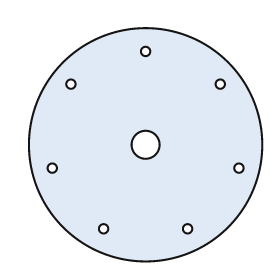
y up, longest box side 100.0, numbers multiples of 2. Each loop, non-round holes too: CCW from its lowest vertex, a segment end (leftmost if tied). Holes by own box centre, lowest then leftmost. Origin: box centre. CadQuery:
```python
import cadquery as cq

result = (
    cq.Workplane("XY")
    .moveTo(0.0, 0.0)
    .circle(50.0)
    .moveTo(-18.0, -36.0)
    .circle(2.0)
    .moveTo(18.0, -36.0)
    .circle(2.0)
    .moveTo(-40.0, -10.0)
    .circle(2.0)
    .moveTo(40.0, -10.0)
    .circle(2.0)
    .moveTo(0.0, 0.0)
    .circle(6.0)
    .moveTo(-32.0, 26.0)
    .circle(2.0)
    .moveTo(32.0, 26.0)
    .circle(2.0)
    .moveTo(0.0, 40.0)
    .circle(2.0)
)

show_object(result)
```